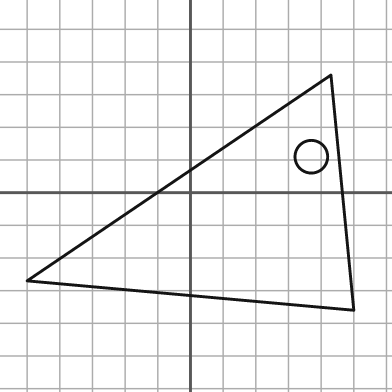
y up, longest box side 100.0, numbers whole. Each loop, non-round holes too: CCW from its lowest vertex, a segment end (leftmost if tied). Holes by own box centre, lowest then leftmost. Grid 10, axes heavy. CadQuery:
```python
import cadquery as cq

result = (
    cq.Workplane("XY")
    .moveTo(50.0, -36.0)
    .lineTo(43.0, 36.0)
    .lineTo(-50.0, -27.0)
    .close()
    .moveTo(37.0, 11.0)
    .circle(5.0)
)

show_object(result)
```